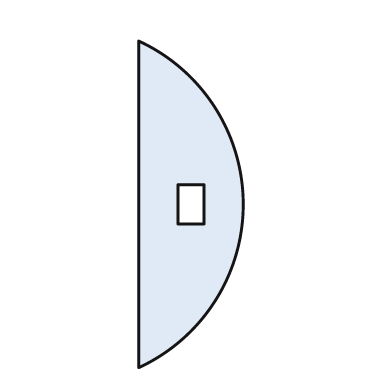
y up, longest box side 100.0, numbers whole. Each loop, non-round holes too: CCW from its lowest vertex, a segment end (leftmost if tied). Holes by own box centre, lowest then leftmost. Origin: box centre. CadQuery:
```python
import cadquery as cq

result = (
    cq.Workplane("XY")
    .moveTo(-16.0, -50.0)
    .threePointArc((16.0, 0.0), (-16.0, 50.0))
    .close()
    .moveTo(-4.0, -6.0)
    .lineTo(4.0, -6.0)
    .lineTo(4.0, 6.0)
    .lineTo(-4.0, 6.0)
    .close()
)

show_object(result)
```